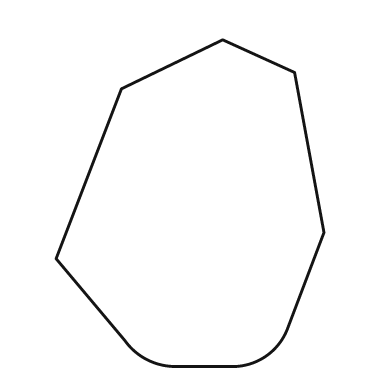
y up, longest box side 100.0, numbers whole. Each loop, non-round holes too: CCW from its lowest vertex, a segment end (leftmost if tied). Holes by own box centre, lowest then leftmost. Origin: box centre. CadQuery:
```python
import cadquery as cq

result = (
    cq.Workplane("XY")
    .moveTo(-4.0, -50.0)
    .lineTo(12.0, -50.0)
    .threePointArc((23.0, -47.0), (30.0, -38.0))
    .lineTo(41.0, -9.0)
    .lineTo(32.0, 40.0)
    .lineTo(10.0, 50.0)
    .lineTo(-21.0, 35.0)
    .lineTo(-41.0, -17.0)
    .lineTo(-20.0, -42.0)
    .threePointArc((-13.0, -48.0), (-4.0, -50.0))
    .close()
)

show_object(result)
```